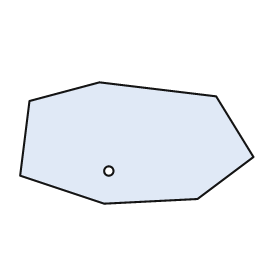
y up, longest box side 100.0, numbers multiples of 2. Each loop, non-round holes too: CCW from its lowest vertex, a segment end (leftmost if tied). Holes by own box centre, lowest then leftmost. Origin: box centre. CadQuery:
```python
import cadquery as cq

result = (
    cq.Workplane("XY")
    .moveTo(-14.0, -26.0)
    .lineTo(26.0, -24.0)
    .lineTo(50.0, -6.0)
    .lineTo(34.0, 20.0)
    .lineTo(-16.0, 26.0)
    .lineTo(-46.0, 18.0)
    .lineTo(-50.0, -14.0)
    .close()
    .moveTo(-12.0, -12.0)
    .circle(2.0)
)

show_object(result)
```